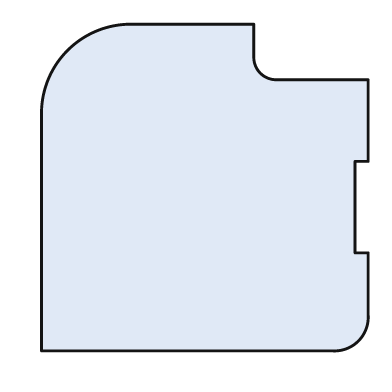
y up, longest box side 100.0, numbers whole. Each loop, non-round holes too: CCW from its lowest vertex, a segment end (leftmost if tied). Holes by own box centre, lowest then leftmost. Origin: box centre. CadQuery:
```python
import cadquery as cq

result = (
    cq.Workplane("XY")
    .moveTo(-50.0, -50.0)
    .lineTo(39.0, -50.0)
    .threePointArc((47.0, -47.0), (50.0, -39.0))
    .lineTo(50.0, -20.0)
    .lineTo(46.0, -20.0)
    .lineTo(46.0, 8.0)
    .lineTo(50.0, 8.0)
    .lineTo(50.0, 33.0)
    .lineTo(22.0, 33.0)
    .threePointArc((17.0, 35.0), (15.0, 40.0))
    .lineTo(15.0, 50.0)
    .lineTo(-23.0, 50.0)
    .threePointArc((-42.0, 42.0), (-50.0, 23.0))
    .close()
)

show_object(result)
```